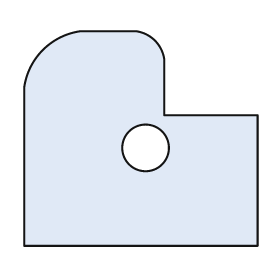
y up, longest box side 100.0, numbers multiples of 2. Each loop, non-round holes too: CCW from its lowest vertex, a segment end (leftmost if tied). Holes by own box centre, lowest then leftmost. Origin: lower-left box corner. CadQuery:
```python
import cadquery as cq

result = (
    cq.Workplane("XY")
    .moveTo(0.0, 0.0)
    .lineTo(100.0, 0.0)
    .lineTo(100.0, 56.0)
    .lineTo(60.0, 56.0)
    .lineTo(60.0, 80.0)
    .threePointArc((56.0, 88.0), (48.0, 92.0))
    .lineTo(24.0, 92.0)
    .threePointArc((8.0, 84.0), (0.0, 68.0))
    .close()
    .moveTo(52.0, 42.0)
    .circle(10.0)
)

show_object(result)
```